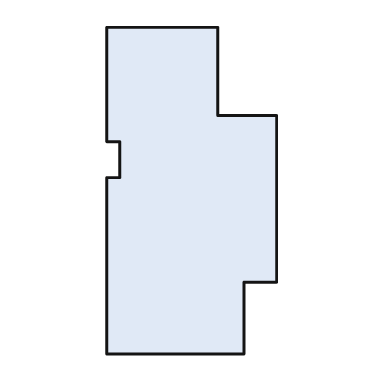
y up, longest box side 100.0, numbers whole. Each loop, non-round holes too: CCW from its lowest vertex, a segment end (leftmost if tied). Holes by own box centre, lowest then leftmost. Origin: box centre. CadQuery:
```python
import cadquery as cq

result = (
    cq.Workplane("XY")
    .moveTo(-26.0, -50.0)
    .lineTo(16.0, -50.0)
    .lineTo(16.0, -28.0)
    .lineTo(26.0, -28.0)
    .lineTo(26.0, 23.0)
    .lineTo(8.0, 23.0)
    .lineTo(8.0, 50.0)
    .lineTo(-26.0, 50.0)
    .lineTo(-26.0, 15.0)
    .lineTo(-22.0, 15.0)
    .lineTo(-22.0, 4.0)
    .lineTo(-26.0, 4.0)
    .close()
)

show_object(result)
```